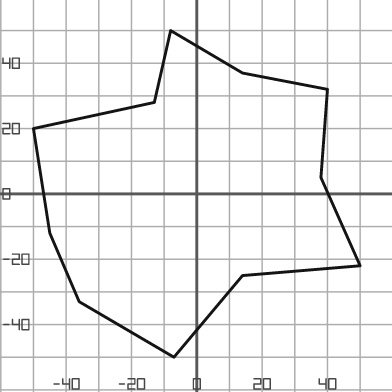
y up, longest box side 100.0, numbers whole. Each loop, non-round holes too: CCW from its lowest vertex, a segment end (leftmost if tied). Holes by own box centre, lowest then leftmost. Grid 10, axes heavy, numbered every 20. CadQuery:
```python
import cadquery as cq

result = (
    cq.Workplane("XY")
    .moveTo(-7.0, -50.0)
    .lineTo(14.0, -25.0)
    .lineTo(50.0, -22.0)
    .lineTo(38.0, 5.0)
    .lineTo(40.0, 32.0)
    .lineTo(14.0, 37.0)
    .lineTo(-8.0, 50.0)
    .lineTo(-13.0, 28.0)
    .lineTo(-50.0, 20.0)
    .lineTo(-45.0, -12.0)
    .lineTo(-36.0, -33.0)
    .close()
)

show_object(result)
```